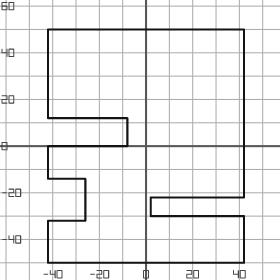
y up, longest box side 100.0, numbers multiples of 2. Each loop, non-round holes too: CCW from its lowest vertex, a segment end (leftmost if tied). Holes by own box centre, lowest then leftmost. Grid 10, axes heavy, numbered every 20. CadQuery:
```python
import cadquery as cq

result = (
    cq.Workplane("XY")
    .moveTo(-42.0, -50.0)
    .lineTo(42.0, -50.0)
    .lineTo(42.0, -30.0)
    .lineTo(2.0, -30.0)
    .lineTo(2.0, -22.0)
    .lineTo(42.0, -22.0)
    .lineTo(42.0, 50.0)
    .lineTo(-42.0, 50.0)
    .lineTo(-42.0, 12.0)
    .lineTo(-8.0, 12.0)
    .lineTo(-8.0, 0.0)
    .lineTo(-42.0, 0.0)
    .lineTo(-42.0, -14.0)
    .lineTo(-26.0, -14.0)
    .lineTo(-26.0, -32.0)
    .lineTo(-42.0, -32.0)
    .close()
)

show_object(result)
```